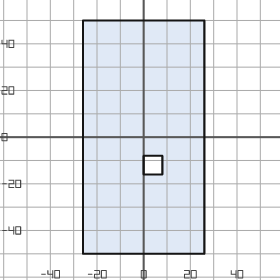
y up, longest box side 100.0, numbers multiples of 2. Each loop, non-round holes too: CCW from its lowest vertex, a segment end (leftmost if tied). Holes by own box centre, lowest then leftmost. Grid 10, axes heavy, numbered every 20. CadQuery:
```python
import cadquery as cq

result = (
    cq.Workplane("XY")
    .moveTo(-26.0, -50.0)
    .lineTo(26.0, -50.0)
    .lineTo(26.0, 50.0)
    .lineTo(-26.0, 50.0)
    .close()
    .moveTo(0.0, -16.0)
    .lineTo(8.0, -16.0)
    .lineTo(8.0, -8.0)
    .lineTo(0.0, -8.0)
    .close()
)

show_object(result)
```